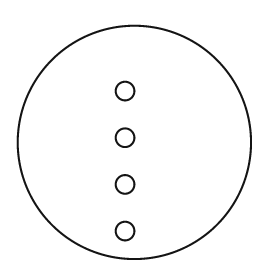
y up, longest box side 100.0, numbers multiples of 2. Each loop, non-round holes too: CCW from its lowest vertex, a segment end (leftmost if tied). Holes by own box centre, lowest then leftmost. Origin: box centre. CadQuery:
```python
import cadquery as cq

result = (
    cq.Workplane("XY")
    .moveTo(0.0, 0.0)
    .circle(50.0)
    .moveTo(-4.0, -38.0)
    .circle(4.0)
    .moveTo(-4.0, -18.0)
    .circle(4.0)
    .moveTo(-4.0, 2.0)
    .circle(4.0)
    .moveTo(-4.0, 22.0)
    .circle(4.0)
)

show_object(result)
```